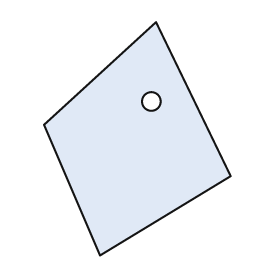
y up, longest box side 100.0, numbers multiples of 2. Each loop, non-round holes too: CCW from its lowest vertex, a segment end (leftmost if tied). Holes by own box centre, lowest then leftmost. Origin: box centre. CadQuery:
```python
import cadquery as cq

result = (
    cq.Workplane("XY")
    .moveTo(-16.0, -50.0)
    .lineTo(40.0, -16.0)
    .lineTo(8.0, 50.0)
    .lineTo(-40.0, 6.0)
    .close()
    .moveTo(6.0, 16.0)
    .circle(4.0)
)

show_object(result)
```